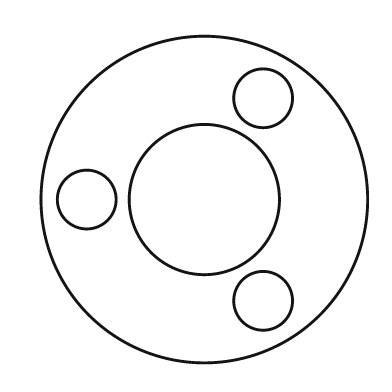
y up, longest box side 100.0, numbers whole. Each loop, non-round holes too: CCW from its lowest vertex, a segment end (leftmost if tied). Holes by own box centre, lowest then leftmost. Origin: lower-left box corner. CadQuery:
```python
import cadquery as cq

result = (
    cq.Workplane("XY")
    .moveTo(50.0, 50.0)
    .circle(50.0)
    .moveTo(68.0, 19.0)
    .circle(9.0)
    .moveTo(14.0, 50.0)
    .circle(9.0)
    .moveTo(50.0, 50.0)
    .circle(23.0)
    .moveTo(68.0, 81.0)
    .circle(9.0)
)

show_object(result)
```